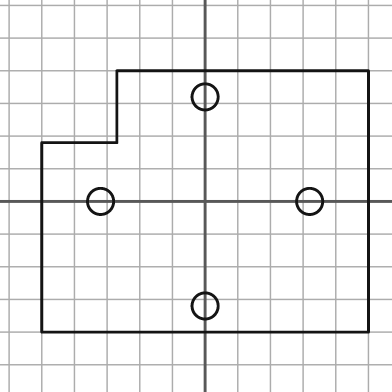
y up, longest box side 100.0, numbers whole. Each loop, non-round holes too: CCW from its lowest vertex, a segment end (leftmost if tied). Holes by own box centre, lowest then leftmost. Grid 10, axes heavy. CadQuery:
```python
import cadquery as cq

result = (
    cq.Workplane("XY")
    .moveTo(-50.0, -40.0)
    .lineTo(50.0, -40.0)
    .lineTo(50.0, 40.0)
    .lineTo(-27.0, 40.0)
    .lineTo(-27.0, 18.0)
    .lineTo(-50.0, 18.0)
    .close()
    .moveTo(0.0, -32.0)
    .circle(4.0)
    .moveTo(-32.0, 0.0)
    .circle(4.0)
    .moveTo(32.0, 0.0)
    .circle(4.0)
    .moveTo(0.0, 32.0)
    .circle(4.0)
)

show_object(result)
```